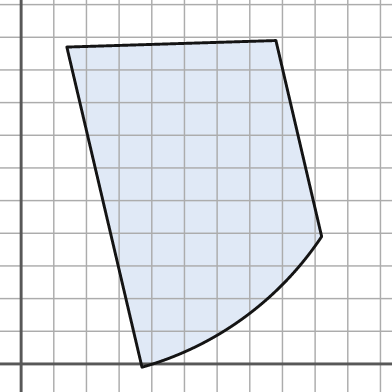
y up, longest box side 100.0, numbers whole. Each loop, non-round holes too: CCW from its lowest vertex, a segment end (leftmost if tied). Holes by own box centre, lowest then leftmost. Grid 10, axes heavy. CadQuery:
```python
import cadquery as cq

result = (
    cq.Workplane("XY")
    .moveTo(37.0, -1.0)
    .threePointArc((68.0, 14.0), (92.0, 39.0))
    .lineTo(78.0, 99.0)
    .lineTo(14.0, 97.0)
    .close()
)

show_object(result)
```